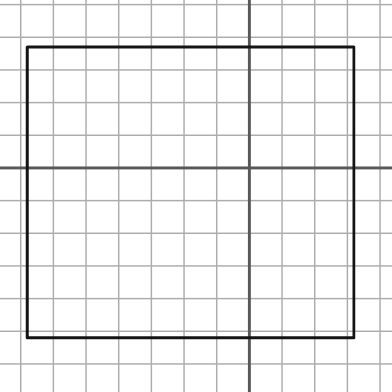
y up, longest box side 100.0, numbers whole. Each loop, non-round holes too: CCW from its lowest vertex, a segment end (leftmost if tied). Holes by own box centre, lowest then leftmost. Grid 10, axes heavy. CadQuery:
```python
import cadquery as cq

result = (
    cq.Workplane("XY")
    .moveTo(-68.0, -52.0)
    .lineTo(32.0, -52.0)
    .lineTo(32.0, 37.0)
    .lineTo(-68.0, 37.0)
    .close()
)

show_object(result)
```